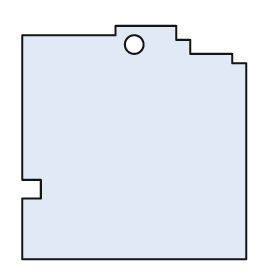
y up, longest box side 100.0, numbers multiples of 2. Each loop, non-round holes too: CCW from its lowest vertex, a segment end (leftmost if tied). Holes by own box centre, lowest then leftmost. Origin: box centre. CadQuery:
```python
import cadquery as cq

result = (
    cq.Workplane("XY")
    .moveTo(-48.0, -50.0)
    .lineTo(48.0, -50.0)
    .lineTo(48.0, 34.0)
    .lineTo(42.0, 34.0)
    .lineTo(42.0, 38.0)
    .lineTo(24.0, 38.0)
    .lineTo(24.0, 44.0)
    .lineTo(18.0, 44.0)
    .lineTo(18.0, 50.0)
    .lineTo(-8.0, 50.0)
    .lineTo(-8.0, 46.0)
    .lineTo(-48.0, 46.0)
    .lineTo(-48.0, -16.0)
    .lineTo(-40.0, -16.0)
    .lineTo(-40.0, -24.0)
    .lineTo(-48.0, -24.0)
    .close()
    .moveTo(0.0, 42.0)
    .circle(4.0)
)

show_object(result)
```